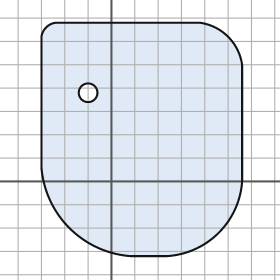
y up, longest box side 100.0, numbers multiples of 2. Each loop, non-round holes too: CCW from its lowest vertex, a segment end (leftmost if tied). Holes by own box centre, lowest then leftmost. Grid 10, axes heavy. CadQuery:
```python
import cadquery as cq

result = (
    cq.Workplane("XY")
    .moveTo(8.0, -32.0)
    .lineTo(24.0, -32.0)
    .threePointArc((46.0, -22.0), (56.0, 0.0))
    .lineTo(56.0, 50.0)
    .threePointArc((50.0, 62.0), (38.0, 68.0))
    .lineTo(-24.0, 68.0)
    .threePointArc((-28.0, 66.0), (-30.0, 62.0))
    .lineTo(-30.0, 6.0)
    .threePointArc((-18.0, -20.0), (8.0, -32.0))
    .close()
    .moveTo(-10.0, 38.0)
    .circle(4.0)
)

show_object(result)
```